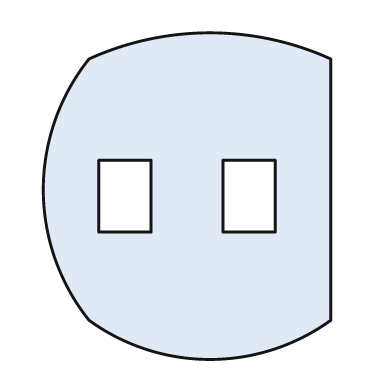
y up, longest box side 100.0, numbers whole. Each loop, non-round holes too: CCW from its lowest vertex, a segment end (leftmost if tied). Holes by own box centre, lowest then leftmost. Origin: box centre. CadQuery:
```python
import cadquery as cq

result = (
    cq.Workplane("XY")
    .moveTo(-30.0, -38.0)
    .threePointArc((7.0, -50.0), (44.0, -38.0))
    .lineTo(44.0, 42.0)
    .threePointArc((7.0, 50.0), (-30.0, 42.0))
    .threePointArc((-44.0, 2.0), (-30.0, -38.0))
    .close()
    .moveTo(-27.0, -11.0)
    .lineTo(-11.0, -11.0)
    .lineTo(-11.0, 11.0)
    .lineTo(-27.0, 11.0)
    .close()
    .moveTo(11.0, -11.0)
    .lineTo(27.0, -11.0)
    .lineTo(27.0, 11.0)
    .lineTo(11.0, 11.0)
    .close()
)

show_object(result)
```